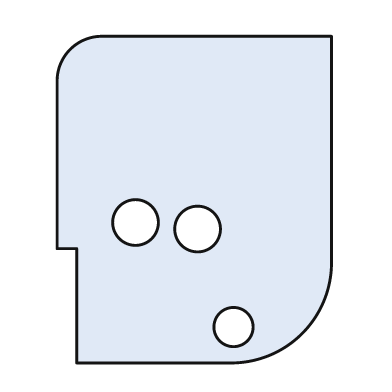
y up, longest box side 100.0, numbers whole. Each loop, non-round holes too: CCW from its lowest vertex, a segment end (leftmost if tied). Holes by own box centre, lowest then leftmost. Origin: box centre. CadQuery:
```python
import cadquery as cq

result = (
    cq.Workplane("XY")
    .moveTo(-36.0, -50.0)
    .lineTo(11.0, -50.0)
    .threePointArc((33.0, -41.0), (42.0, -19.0))
    .lineTo(42.0, 50.0)
    .lineTo(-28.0, 50.0)
    .threePointArc((-38.0, 46.0), (-42.0, 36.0))
    .lineTo(-42.0, -15.0)
    .lineTo(-36.0, -15.0)
    .close()
    .moveTo(12.0, -39.0)
    .circle(6.0)
    .moveTo(1.0, -9.0)
    .circle(7.0)
    .moveTo(-18.0, -7.0)
    .circle(7.0)
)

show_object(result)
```